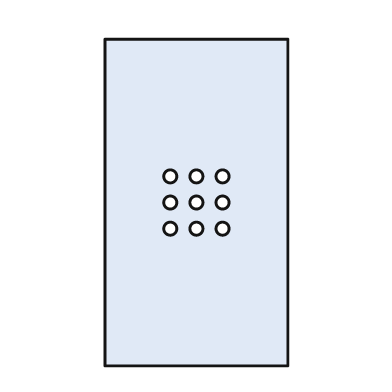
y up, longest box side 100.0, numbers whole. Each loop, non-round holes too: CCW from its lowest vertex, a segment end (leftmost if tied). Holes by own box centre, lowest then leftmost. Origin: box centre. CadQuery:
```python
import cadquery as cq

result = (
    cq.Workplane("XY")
    .moveTo(-28.0, -50.0)
    .lineTo(28.0, -50.0)
    .lineTo(28.0, 50.0)
    .lineTo(-28.0, 50.0)
    .close()
    .moveTo(-8.0, -8.0)
    .circle(2.0)
    .moveTo(0.0, -8.0)
    .circle(2.0)
    .moveTo(8.0, -8.0)
    .circle(2.0)
    .moveTo(-8.0, 0.0)
    .circle(2.0)
    .moveTo(0.0, 0.0)
    .circle(2.0)
    .moveTo(8.0, 0.0)
    .circle(2.0)
    .moveTo(-8.0, 8.0)
    .circle(2.0)
    .moveTo(0.0, 8.0)
    .circle(2.0)
    .moveTo(8.0, 8.0)
    .circle(2.0)
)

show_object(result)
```